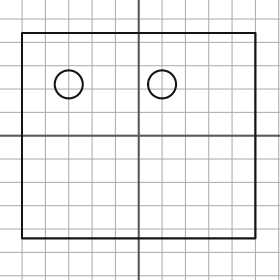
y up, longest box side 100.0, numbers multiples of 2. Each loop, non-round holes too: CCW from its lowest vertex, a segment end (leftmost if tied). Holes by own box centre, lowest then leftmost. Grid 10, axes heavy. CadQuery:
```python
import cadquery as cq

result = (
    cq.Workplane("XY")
    .moveTo(-50.0, -44.0)
    .lineTo(50.0, -44.0)
    .lineTo(50.0, 44.0)
    .lineTo(-50.0, 44.0)
    .close()
    .moveTo(-30.0, 22.0)
    .circle(6.0)
    .moveTo(10.0, 22.0)
    .circle(6.0)
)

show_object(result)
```